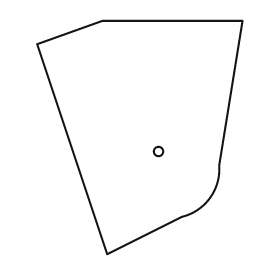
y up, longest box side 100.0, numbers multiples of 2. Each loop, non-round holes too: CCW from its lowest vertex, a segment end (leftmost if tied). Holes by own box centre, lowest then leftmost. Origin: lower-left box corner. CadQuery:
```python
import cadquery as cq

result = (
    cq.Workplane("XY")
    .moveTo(30.0, 0.0)
    .lineTo(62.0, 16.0)
    .threePointArc((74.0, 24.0), (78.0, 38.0))
    .lineTo(88.0, 100.0)
    .lineTo(28.0, 100.0)
    .lineTo(0.0, 90.0)
    .close()
    .moveTo(52.0, 44.0)
    .circle(2.0)
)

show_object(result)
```